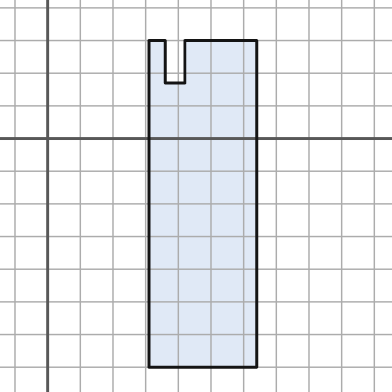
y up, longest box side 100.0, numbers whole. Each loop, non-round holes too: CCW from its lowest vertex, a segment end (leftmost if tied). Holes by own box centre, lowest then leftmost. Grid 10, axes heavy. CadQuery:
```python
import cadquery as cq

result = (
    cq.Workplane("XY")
    .moveTo(31.0, -70.0)
    .lineTo(64.0, -70.0)
    .lineTo(64.0, 30.0)
    .lineTo(42.0, 30.0)
    .lineTo(42.0, 17.0)
    .lineTo(36.0, 17.0)
    .lineTo(36.0, 30.0)
    .lineTo(31.0, 30.0)
    .close()
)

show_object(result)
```